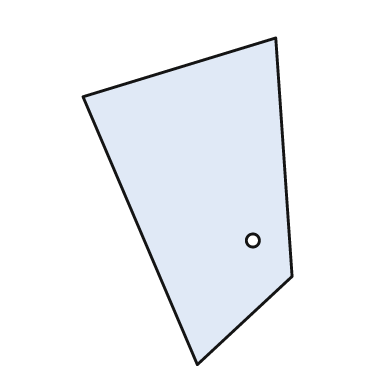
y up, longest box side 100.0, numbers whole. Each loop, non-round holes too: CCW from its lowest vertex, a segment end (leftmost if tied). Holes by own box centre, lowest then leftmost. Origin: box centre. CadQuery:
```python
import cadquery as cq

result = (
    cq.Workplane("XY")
    .moveTo(3.0, -50.0)
    .lineTo(32.0, -23.0)
    .lineTo(27.0, 50.0)
    .lineTo(-32.0, 32.0)
    .close()
    .moveTo(20.0, -12.0)
    .circle(2.0)
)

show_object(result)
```